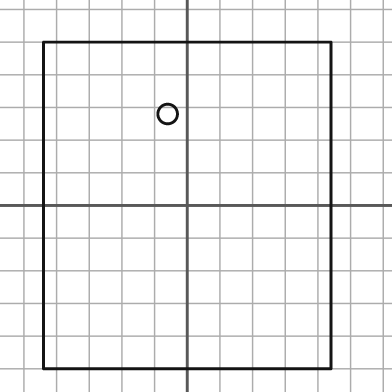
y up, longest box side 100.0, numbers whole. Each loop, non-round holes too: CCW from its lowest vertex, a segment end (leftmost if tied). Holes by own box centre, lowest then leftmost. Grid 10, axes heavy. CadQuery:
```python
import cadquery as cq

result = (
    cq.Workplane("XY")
    .moveTo(-44.0, -50.0)
    .lineTo(44.0, -50.0)
    .lineTo(44.0, 50.0)
    .lineTo(-44.0, 50.0)
    .close()
    .moveTo(-6.0, 28.0)
    .circle(3.0)
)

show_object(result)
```